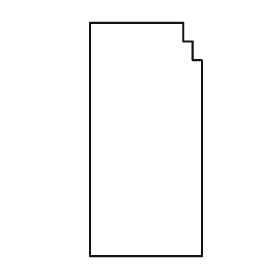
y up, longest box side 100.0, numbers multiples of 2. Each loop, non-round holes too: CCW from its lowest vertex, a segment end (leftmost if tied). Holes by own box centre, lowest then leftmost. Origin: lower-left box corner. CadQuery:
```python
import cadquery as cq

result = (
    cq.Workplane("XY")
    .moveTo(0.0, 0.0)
    .lineTo(48.0, 0.0)
    .lineTo(48.0, 84.0)
    .lineTo(44.0, 84.0)
    .lineTo(44.0, 92.0)
    .lineTo(40.0, 92.0)
    .lineTo(40.0, 100.0)
    .lineTo(0.0, 100.0)
    .close()
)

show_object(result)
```